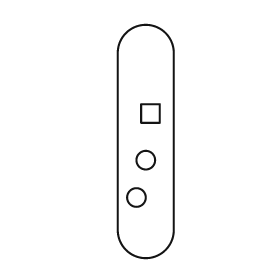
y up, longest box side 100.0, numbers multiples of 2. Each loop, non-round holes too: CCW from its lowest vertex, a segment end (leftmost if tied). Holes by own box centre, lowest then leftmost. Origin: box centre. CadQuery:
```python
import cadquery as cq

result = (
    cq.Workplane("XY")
    .moveTo(-12.0, -38.0)
    .threePointArc((0.0, -50.0), (12.0, -38.0))
    .lineTo(12.0, 38.0)
    .threePointArc((0.0, 50.0), (-12.0, 38.0))
    .close()
    .moveTo(-4.0, -24.0)
    .circle(4.0)
    .moveTo(0.0, -8.0)
    .circle(4.0)
    .moveTo(-2.0, 8.0)
    .lineTo(6.0, 8.0)
    .lineTo(6.0, 16.0)
    .lineTo(-2.0, 16.0)
    .close()
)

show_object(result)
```